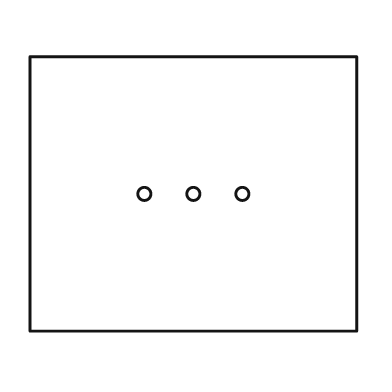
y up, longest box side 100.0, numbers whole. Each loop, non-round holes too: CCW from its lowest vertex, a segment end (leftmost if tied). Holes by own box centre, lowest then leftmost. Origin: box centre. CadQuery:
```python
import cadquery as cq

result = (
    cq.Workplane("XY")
    .moveTo(-50.0, -42.0)
    .lineTo(50.0, -42.0)
    .lineTo(50.0, 42.0)
    .lineTo(-50.0, 42.0)
    .close()
    .moveTo(-15.0, 0.0)
    .circle(2.0)
    .moveTo(0.0, 0.0)
    .circle(2.0)
    .moveTo(15.0, 0.0)
    .circle(2.0)
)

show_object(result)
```